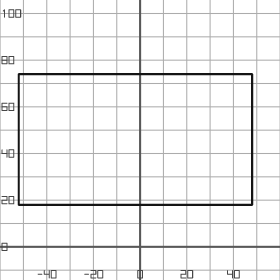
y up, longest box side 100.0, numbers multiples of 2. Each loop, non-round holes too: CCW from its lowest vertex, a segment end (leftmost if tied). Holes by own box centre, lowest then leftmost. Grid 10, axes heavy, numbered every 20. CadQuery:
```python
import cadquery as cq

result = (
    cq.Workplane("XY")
    .moveTo(-52.0, 18.0)
    .lineTo(48.0, 18.0)
    .lineTo(48.0, 74.0)
    .lineTo(-52.0, 74.0)
    .close()
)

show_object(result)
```